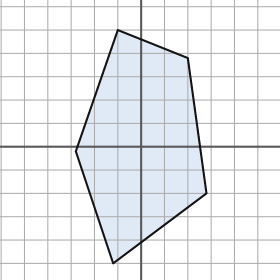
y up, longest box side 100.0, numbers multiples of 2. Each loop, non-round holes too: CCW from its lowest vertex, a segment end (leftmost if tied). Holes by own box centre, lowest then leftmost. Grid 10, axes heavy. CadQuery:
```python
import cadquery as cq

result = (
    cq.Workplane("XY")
    .moveTo(-12.0, -50.0)
    .lineTo(28.0, -20.0)
    .lineTo(20.0, 38.0)
    .lineTo(-10.0, 50.0)
    .lineTo(-28.0, -2.0)
    .close()
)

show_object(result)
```